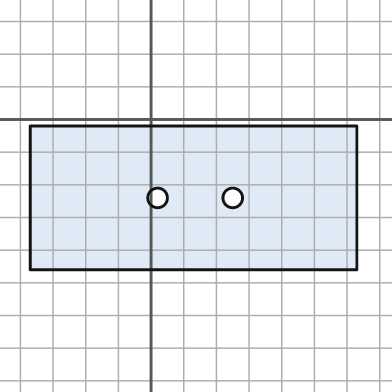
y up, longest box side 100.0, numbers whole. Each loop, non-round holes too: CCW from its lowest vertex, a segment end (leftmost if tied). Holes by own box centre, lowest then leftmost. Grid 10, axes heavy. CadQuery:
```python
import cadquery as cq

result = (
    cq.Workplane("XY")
    .moveTo(-37.0, -46.0)
    .lineTo(63.0, -46.0)
    .lineTo(63.0, -2.0)
    .lineTo(-37.0, -2.0)
    .close()
    .moveTo(2.0, -24.0)
    .circle(3.0)
    .moveTo(25.0, -24.0)
    .circle(3.0)
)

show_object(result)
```